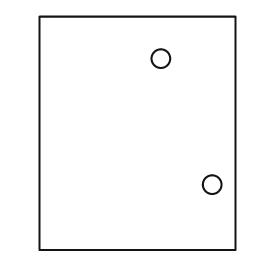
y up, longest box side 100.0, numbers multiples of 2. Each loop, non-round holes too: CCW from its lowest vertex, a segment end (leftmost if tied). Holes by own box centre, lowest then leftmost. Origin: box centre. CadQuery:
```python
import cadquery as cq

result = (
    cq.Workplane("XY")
    .moveTo(-42.0, -50.0)
    .lineTo(42.0, -50.0)
    .lineTo(42.0, 50.0)
    .lineTo(-42.0, 50.0)
    .close()
    .moveTo(32.0, -22.0)
    .circle(4.0)
    .moveTo(10.0, 32.0)
    .circle(4.0)
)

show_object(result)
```